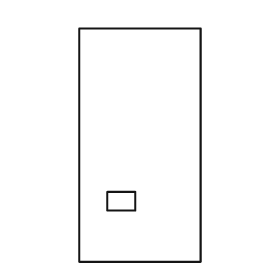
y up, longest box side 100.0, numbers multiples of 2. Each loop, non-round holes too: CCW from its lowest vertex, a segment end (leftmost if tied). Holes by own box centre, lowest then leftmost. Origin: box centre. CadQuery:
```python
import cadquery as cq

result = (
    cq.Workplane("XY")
    .moveTo(-26.0, -50.0)
    .lineTo(26.0, -50.0)
    .lineTo(26.0, 50.0)
    .lineTo(-26.0, 50.0)
    .close()
    .moveTo(-14.0, -28.0)
    .lineTo(-2.0, -28.0)
    .lineTo(-2.0, -20.0)
    .lineTo(-14.0, -20.0)
    .close()
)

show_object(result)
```